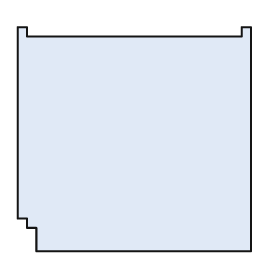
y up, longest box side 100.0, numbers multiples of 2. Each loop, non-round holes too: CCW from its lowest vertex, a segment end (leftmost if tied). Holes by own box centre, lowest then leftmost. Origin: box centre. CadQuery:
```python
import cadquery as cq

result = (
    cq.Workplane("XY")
    .moveTo(-42.0, -48.0)
    .lineTo(50.0, -48.0)
    .lineTo(50.0, 48.0)
    .lineTo(46.0, 48.0)
    .lineTo(46.0, 44.0)
    .lineTo(-46.0, 44.0)
    .lineTo(-46.0, 48.0)
    .lineTo(-50.0, 48.0)
    .lineTo(-50.0, -34.0)
    .lineTo(-46.0, -34.0)
    .lineTo(-46.0, -38.0)
    .lineTo(-42.0, -38.0)
    .close()
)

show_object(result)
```